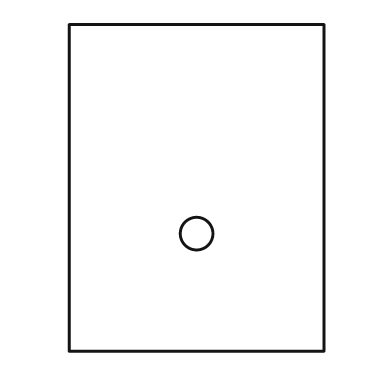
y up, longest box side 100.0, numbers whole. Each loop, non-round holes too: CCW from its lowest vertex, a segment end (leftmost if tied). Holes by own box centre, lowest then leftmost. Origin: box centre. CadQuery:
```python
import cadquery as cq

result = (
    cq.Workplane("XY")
    .moveTo(-39.0, -50.0)
    .lineTo(39.0, -50.0)
    .lineTo(39.0, 50.0)
    .lineTo(-39.0, 50.0)
    .close()
    .moveTo(0.0, -14.0)
    .circle(5.0)
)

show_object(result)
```